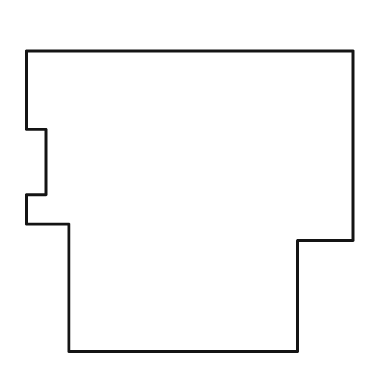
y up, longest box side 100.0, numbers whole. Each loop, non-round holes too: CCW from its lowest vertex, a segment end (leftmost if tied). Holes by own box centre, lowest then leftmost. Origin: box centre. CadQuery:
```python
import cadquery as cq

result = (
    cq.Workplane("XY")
    .moveTo(-37.0, -46.0)
    .lineTo(33.0, -46.0)
    .lineTo(33.0, -12.0)
    .lineTo(50.0, -12.0)
    .lineTo(50.0, 46.0)
    .lineTo(-50.0, 46.0)
    .lineTo(-50.0, 22.0)
    .lineTo(-44.0, 22.0)
    .lineTo(-44.0, 2.0)
    .lineTo(-50.0, 2.0)
    .lineTo(-50.0, -7.0)
    .lineTo(-37.0, -7.0)
    .close()
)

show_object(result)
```